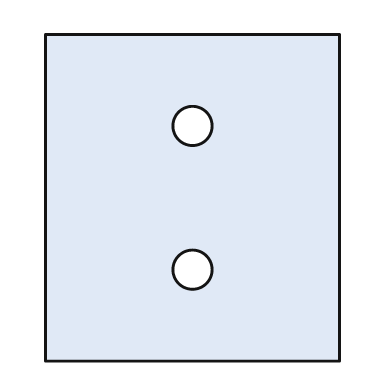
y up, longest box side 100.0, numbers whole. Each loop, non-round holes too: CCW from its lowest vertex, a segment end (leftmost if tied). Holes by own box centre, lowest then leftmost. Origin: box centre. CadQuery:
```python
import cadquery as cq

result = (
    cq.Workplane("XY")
    .moveTo(-45.0, -50.0)
    .lineTo(45.0, -50.0)
    .lineTo(45.0, 50.0)
    .lineTo(-45.0, 50.0)
    .close()
    .moveTo(0.0, -22.0)
    .circle(6.0)
    .moveTo(0.0, 22.0)
    .circle(6.0)
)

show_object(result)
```